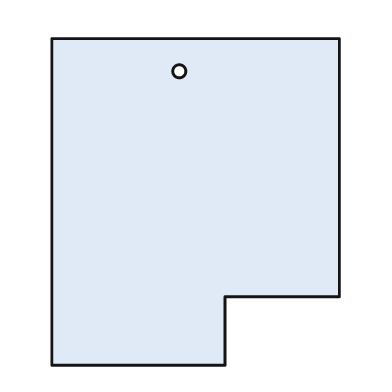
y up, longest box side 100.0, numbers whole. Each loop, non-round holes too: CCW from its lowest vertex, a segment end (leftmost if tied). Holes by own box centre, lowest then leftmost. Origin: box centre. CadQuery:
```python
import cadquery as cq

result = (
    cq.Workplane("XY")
    .moveTo(-44.0, -50.0)
    .lineTo(9.0, -50.0)
    .lineTo(9.0, -29.0)
    .lineTo(44.0, -29.0)
    .lineTo(44.0, 50.0)
    .lineTo(-44.0, 50.0)
    .close()
    .moveTo(-5.0, 40.0)
    .circle(2.0)
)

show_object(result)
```